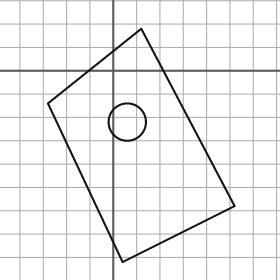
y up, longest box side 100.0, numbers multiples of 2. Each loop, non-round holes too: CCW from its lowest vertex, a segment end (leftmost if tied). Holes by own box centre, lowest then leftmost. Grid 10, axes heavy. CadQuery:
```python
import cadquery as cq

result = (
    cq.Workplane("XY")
    .moveTo(4.0, -82.0)
    .lineTo(52.0, -58.0)
    .lineTo(12.0, 18.0)
    .lineTo(-28.0, -14.0)
    .close()
    .moveTo(6.0, -22.0)
    .circle(8.0)
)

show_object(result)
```